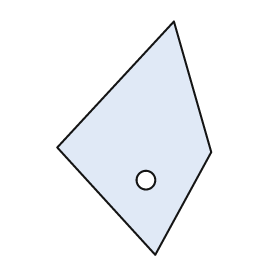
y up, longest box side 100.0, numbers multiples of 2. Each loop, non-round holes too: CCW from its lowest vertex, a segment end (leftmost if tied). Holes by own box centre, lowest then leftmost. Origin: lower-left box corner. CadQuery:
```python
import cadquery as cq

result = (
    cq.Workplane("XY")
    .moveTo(42.0, 0.0)
    .lineTo(66.0, 44.0)
    .lineTo(50.0, 100.0)
    .lineTo(0.0, 46.0)
    .close()
    .moveTo(38.0, 32.0)
    .circle(4.0)
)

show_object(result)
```